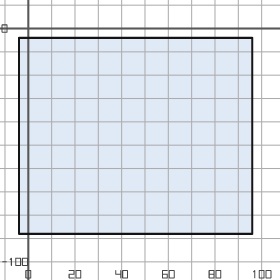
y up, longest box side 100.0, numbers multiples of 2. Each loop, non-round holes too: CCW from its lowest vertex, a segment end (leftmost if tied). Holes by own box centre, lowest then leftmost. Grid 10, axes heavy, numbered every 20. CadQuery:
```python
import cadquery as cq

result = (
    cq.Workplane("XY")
    .moveTo(-4.0, -88.0)
    .lineTo(96.0, -88.0)
    .lineTo(96.0, -4.0)
    .lineTo(-4.0, -4.0)
    .close()
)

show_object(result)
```